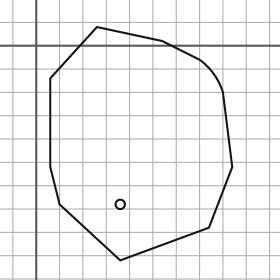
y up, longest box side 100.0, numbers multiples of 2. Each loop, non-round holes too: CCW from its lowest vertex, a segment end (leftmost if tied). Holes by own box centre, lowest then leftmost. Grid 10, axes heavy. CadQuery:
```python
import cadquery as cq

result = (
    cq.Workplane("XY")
    .moveTo(36.0, -92.0)
    .lineTo(74.0, -78.0)
    .lineTo(84.0, -52.0)
    .lineTo(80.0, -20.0)
    .threePointArc((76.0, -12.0), (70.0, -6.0))
    .lineTo(54.0, 2.0)
    .lineTo(26.0, 8.0)
    .lineTo(6.0, -14.0)
    .lineTo(6.0, -52.0)
    .lineTo(10.0, -68.0)
    .close()
    .moveTo(36.0, -68.0)
    .circle(2.0)
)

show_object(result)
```